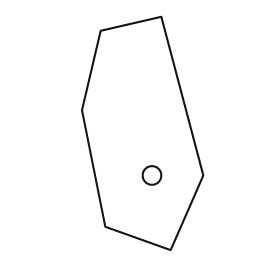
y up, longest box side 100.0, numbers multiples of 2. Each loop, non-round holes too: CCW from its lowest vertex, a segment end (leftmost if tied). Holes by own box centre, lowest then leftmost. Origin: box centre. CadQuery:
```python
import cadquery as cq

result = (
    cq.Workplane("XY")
    .moveTo(12.0, -50.0)
    .lineTo(26.0, -18.0)
    .lineTo(8.0, 50.0)
    .lineTo(-18.0, 44.0)
    .lineTo(-26.0, 10.0)
    .lineTo(-16.0, -40.0)
    .close()
    .moveTo(4.0, -18.0)
    .circle(4.0)
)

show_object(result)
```